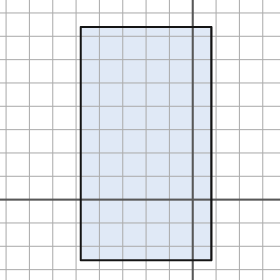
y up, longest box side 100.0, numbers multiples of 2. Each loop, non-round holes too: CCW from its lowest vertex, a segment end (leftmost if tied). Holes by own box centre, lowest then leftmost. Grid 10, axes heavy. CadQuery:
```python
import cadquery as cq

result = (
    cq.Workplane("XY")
    .moveTo(-48.0, -26.0)
    .lineTo(8.0, -26.0)
    .lineTo(8.0, 74.0)
    .lineTo(-48.0, 74.0)
    .close()
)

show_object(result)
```